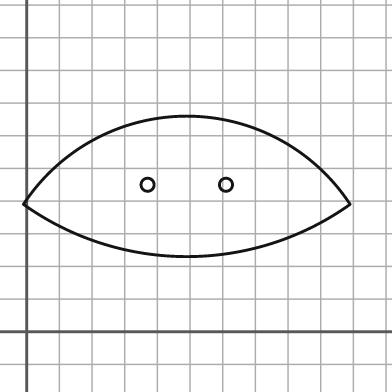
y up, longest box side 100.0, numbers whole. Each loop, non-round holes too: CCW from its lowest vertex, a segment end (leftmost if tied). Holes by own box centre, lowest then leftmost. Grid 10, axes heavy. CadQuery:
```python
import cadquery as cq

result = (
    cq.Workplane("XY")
    .moveTo(-1.0, 39.0)
    .threePointArc((49.0, 23.0), (99.0, 39.0))
    .threePointArc((49.0, 66.0), (-1.0, 39.0))
    .close()
    .moveTo(37.0, 45.0)
    .circle(2.0)
    .moveTo(61.0, 45.0)
    .circle(2.0)
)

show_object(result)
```